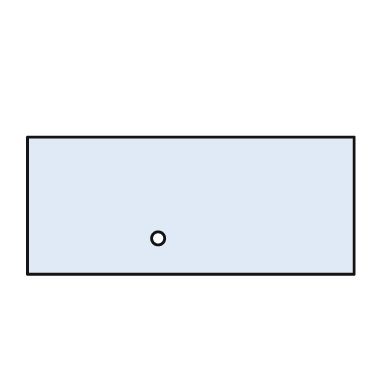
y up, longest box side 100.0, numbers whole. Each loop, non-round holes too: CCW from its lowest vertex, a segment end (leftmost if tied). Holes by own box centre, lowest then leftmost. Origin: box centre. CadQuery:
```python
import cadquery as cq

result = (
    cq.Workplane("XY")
    .moveTo(-50.0, -21.0)
    .lineTo(50.0, -21.0)
    .lineTo(50.0, 21.0)
    .lineTo(-50.0, 21.0)
    .close()
    .moveTo(-10.0, -10.0)
    .circle(2.0)
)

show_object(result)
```